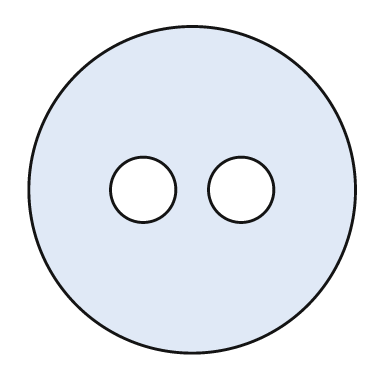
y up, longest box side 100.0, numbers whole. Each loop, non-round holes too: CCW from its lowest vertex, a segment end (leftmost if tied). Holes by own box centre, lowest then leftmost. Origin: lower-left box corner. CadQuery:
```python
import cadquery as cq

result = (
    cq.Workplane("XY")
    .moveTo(50.0, 50.0)
    .circle(50.0)
    .moveTo(35.0, 50.0)
    .circle(10.0)
    .moveTo(65.0, 50.0)
    .circle(10.0)
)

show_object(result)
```